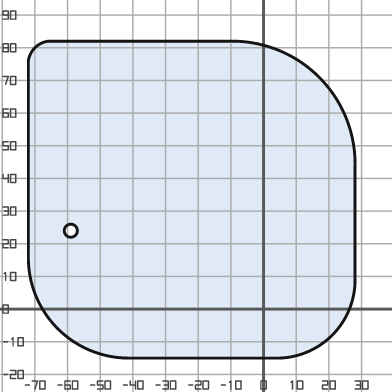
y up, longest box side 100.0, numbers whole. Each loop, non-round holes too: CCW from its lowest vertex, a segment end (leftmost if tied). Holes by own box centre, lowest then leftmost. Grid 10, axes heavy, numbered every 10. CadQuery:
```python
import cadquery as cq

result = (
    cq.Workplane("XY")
    .moveTo(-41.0, -15.0)
    .lineTo(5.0, -15.0)
    .threePointArc((21.0, -8.0), (28.0, 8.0))
    .lineTo(28.0, 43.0)
    .threePointArc((17.0, 71.0), (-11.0, 82.0))
    .lineTo(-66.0, 82.0)
    .threePointArc((-70.0, 80.0), (-72.0, 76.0))
    .lineTo(-72.0, 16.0)
    .threePointArc((-63.0, -6.0), (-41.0, -15.0))
    .close()
    .moveTo(-59.0, 24.0)
    .circle(2.0)
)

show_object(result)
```